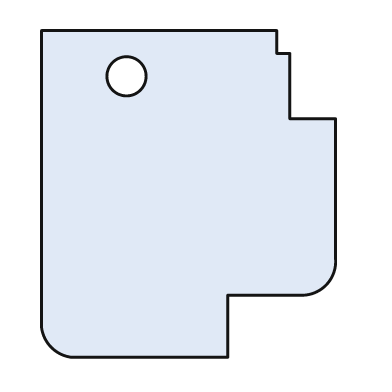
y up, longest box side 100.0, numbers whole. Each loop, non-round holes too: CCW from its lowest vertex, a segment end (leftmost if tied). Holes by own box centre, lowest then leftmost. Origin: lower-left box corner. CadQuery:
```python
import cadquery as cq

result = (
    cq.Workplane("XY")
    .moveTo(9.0, 0.0)
    .lineTo(57.0, 0.0)
    .lineTo(57.0, 19.0)
    .lineTo(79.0, 19.0)
    .threePointArc((87.0, 22.0), (90.0, 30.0))
    .lineTo(90.0, 73.0)
    .lineTo(76.0, 73.0)
    .lineTo(76.0, 93.0)
    .lineTo(72.0, 93.0)
    .lineTo(72.0, 100.0)
    .lineTo(0.0, 100.0)
    .lineTo(0.0, 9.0)
    .threePointArc((3.0, 3.0), (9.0, 0.0))
    .close()
    .moveTo(26.0, 86.0)
    .circle(6.0)
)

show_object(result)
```